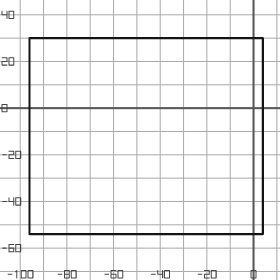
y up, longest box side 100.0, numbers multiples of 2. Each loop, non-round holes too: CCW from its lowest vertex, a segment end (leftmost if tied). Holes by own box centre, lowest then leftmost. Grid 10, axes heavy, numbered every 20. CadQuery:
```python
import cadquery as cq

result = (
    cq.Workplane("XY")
    .moveTo(-96.0, -54.0)
    .lineTo(4.0, -54.0)
    .lineTo(4.0, 30.0)
    .lineTo(-96.0, 30.0)
    .close()
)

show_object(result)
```